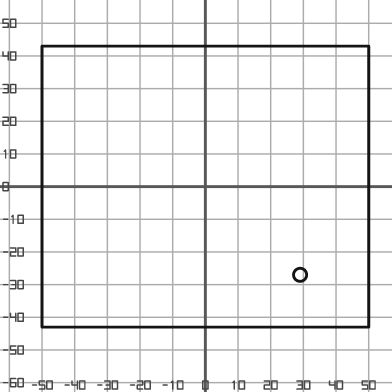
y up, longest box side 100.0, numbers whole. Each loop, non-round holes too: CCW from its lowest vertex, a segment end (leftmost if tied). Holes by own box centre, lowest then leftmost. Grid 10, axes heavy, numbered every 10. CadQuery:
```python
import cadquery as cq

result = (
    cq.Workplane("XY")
    .moveTo(-50.0, -43.0)
    .lineTo(50.0, -43.0)
    .lineTo(50.0, 43.0)
    .lineTo(-50.0, 43.0)
    .close()
    .moveTo(29.0, -27.0)
    .circle(2.0)
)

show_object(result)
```